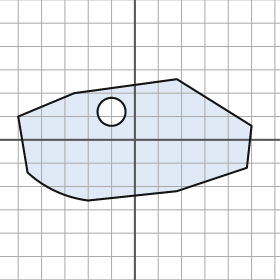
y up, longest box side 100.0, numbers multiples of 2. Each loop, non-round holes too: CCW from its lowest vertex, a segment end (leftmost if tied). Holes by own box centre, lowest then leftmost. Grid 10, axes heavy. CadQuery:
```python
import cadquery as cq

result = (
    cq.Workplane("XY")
    .moveTo(-20.0, -26.0)
    .lineTo(18.0, -22.0)
    .lineTo(48.0, -12.0)
    .lineTo(50.0, 6.0)
    .lineTo(18.0, 26.0)
    .lineTo(-26.0, 20.0)
    .lineTo(-50.0, 10.0)
    .lineTo(-46.0, -14.0)
    .threePointArc((-34.0, -22.0), (-20.0, -26.0))
    .close()
    .moveTo(-10.0, 12.0)
    .circle(6.0)
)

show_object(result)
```